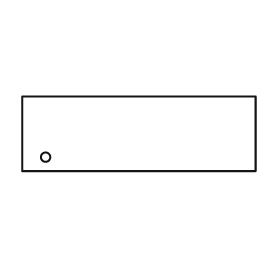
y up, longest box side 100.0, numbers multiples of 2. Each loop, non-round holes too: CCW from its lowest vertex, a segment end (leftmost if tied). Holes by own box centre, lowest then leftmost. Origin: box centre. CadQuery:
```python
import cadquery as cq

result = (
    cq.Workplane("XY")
    .moveTo(-50.0, -16.0)
    .lineTo(50.0, -16.0)
    .lineTo(50.0, 16.0)
    .lineTo(-50.0, 16.0)
    .close()
    .moveTo(-40.0, -10.0)
    .circle(2.0)
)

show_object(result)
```